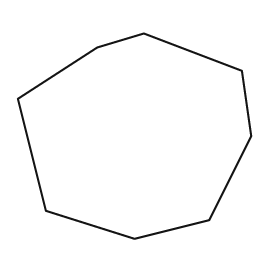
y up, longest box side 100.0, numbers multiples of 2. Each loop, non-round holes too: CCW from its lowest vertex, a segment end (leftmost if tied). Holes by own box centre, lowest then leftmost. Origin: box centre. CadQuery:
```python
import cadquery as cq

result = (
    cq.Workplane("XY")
    .moveTo(0.0, -44.0)
    .lineTo(32.0, -36.0)
    .lineTo(50.0, 0.0)
    .lineTo(46.0, 28.0)
    .lineTo(4.0, 44.0)
    .lineTo(-16.0, 38.0)
    .lineTo(-50.0, 16.0)
    .lineTo(-38.0, -32.0)
    .close()
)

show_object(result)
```